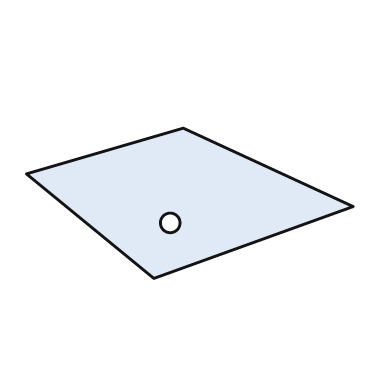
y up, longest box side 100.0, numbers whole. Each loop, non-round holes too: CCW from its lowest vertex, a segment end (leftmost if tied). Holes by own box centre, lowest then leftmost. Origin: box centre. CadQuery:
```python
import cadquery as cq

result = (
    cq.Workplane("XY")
    .moveTo(-11.0, -23.0)
    .lineTo(50.0, -1.0)
    .lineTo(-2.0, 23.0)
    .lineTo(-50.0, 9.0)
    .close()
    .moveTo(-6.0, -6.0)
    .circle(3.0)
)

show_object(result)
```